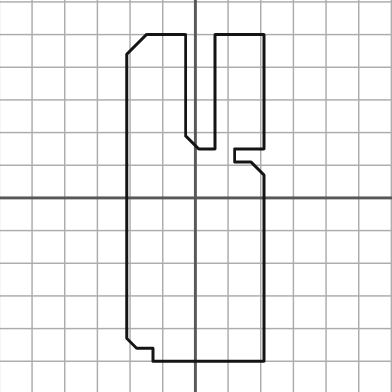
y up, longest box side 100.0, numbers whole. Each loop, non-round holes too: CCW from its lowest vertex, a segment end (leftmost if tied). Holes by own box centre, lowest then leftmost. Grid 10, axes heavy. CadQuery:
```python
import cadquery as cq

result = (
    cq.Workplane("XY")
    .moveTo(-13.0, -50.0)
    .lineTo(21.0, -50.0)
    .lineTo(21.0, 7.0)
    .lineTo(17.0, 11.0)
    .lineTo(12.0, 11.0)
    .lineTo(12.0, 15.0)
    .lineTo(21.0, 15.0)
    .lineTo(21.0, 50.0)
    .lineTo(6.0, 50.0)
    .lineTo(6.0, 15.0)
    .lineTo(1.0, 15.0)
    .lineTo(-3.0, 19.0)
    .lineTo(-3.0, 50.0)
    .lineTo(-15.0, 50.0)
    .lineTo(-21.0, 44.0)
    .lineTo(-21.0, -43.0)
    .lineTo(-18.0, -46.0)
    .lineTo(-13.0, -46.0)
    .close()
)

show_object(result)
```